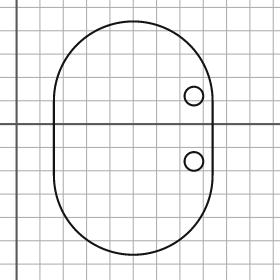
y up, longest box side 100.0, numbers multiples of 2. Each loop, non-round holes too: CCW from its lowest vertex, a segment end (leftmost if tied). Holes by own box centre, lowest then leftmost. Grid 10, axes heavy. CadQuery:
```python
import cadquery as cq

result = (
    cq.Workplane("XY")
    .moveTo(16.0, -22.0)
    .threePointArc((50.0, -56.0), (84.0, -22.0))
    .lineTo(84.0, 10.0)
    .threePointArc((50.0, 44.0), (16.0, 10.0))
    .close()
    .moveTo(76.0, -16.0)
    .circle(4.0)
    .moveTo(76.0, 12.0)
    .circle(4.0)
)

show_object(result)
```